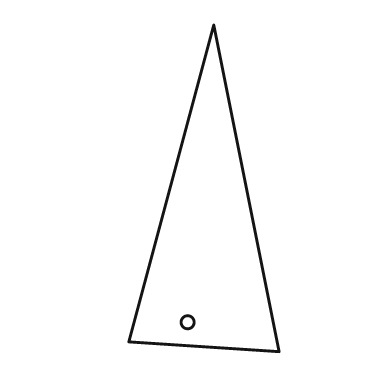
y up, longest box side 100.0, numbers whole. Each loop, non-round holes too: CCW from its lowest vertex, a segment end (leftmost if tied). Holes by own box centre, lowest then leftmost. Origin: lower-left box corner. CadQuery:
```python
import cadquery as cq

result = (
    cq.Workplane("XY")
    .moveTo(46.0, 0.0)
    .lineTo(26.0, 100.0)
    .lineTo(0.0, 3.0)
    .close()
    .moveTo(18.0, 9.0)
    .circle(2.0)
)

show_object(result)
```